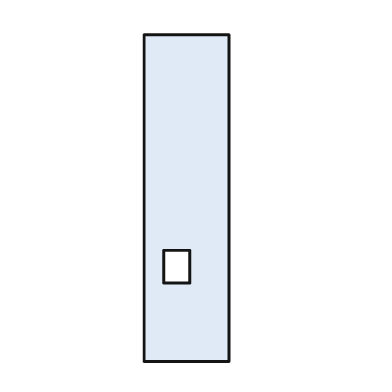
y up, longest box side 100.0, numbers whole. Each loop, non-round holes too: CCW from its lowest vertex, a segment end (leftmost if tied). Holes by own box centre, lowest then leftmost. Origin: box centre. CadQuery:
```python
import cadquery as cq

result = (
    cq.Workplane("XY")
    .moveTo(-13.0, -50.0)
    .lineTo(13.0, -50.0)
    .lineTo(13.0, 50.0)
    .lineTo(-13.0, 50.0)
    .close()
    .moveTo(-7.0, -26.0)
    .lineTo(1.0, -26.0)
    .lineTo(1.0, -16.0)
    .lineTo(-7.0, -16.0)
    .close()
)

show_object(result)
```